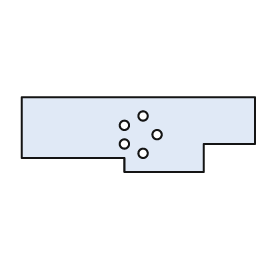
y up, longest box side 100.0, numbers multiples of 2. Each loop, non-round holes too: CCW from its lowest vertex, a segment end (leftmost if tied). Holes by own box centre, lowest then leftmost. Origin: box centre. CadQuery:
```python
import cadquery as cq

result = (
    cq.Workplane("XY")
    .moveTo(-6.0, -16.0)
    .lineTo(28.0, -16.0)
    .lineTo(28.0, -4.0)
    .lineTo(50.0, -4.0)
    .lineTo(50.0, 16.0)
    .lineTo(-50.0, 16.0)
    .lineTo(-50.0, -10.0)
    .lineTo(-6.0, -10.0)
    .close()
    .moveTo(2.0, -8.0)
    .circle(2.0)
    .moveTo(-6.0, -4.0)
    .circle(2.0)
    .moveTo(8.0, 0.0)
    .circle(2.0)
    .moveTo(-6.0, 4.0)
    .circle(2.0)
    .moveTo(2.0, 8.0)
    .circle(2.0)
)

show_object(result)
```